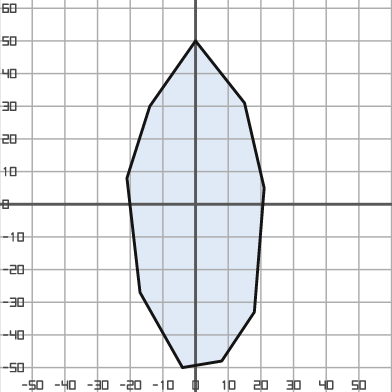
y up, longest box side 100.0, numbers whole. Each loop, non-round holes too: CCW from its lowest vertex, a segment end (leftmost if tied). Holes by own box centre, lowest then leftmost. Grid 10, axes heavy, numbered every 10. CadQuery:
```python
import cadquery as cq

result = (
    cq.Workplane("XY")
    .moveTo(-4.0, -50.0)
    .lineTo(8.0, -48.0)
    .lineTo(18.0, -33.0)
    .lineTo(21.0, 5.0)
    .lineTo(15.0, 31.0)
    .lineTo(0.0, 50.0)
    .lineTo(-14.0, 30.0)
    .lineTo(-21.0, 8.0)
    .lineTo(-17.0, -27.0)
    .close()
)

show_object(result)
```